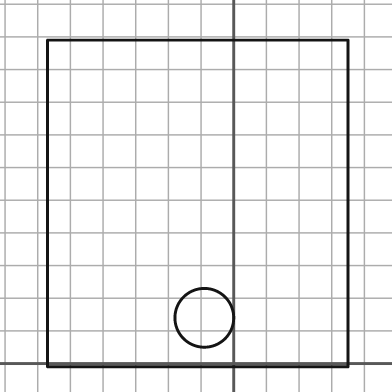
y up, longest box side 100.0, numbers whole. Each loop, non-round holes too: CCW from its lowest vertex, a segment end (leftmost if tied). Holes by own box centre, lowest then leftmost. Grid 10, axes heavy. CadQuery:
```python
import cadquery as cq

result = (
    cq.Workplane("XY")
    .moveTo(-57.0, -1.0)
    .lineTo(35.0, -1.0)
    .lineTo(35.0, 99.0)
    .lineTo(-57.0, 99.0)
    .close()
    .moveTo(-9.0, 14.0)
    .circle(9.0)
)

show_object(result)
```